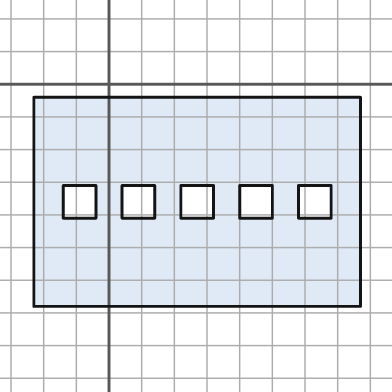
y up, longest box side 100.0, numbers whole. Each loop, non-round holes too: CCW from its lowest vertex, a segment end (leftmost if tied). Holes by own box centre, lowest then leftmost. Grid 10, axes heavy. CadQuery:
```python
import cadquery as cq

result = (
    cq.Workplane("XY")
    .moveTo(-23.0, -68.0)
    .lineTo(77.0, -68.0)
    .lineTo(77.0, -4.0)
    .lineTo(-23.0, -4.0)
    .close()
    .moveTo(-14.0, -41.0)
    .lineTo(-4.0, -41.0)
    .lineTo(-4.0, -31.0)
    .lineTo(-14.0, -31.0)
    .close()
    .moveTo(4.0, -41.0)
    .lineTo(14.0, -41.0)
    .lineTo(14.0, -31.0)
    .lineTo(4.0, -31.0)
    .close()
    .moveTo(22.0, -41.0)
    .lineTo(32.0, -41.0)
    .lineTo(32.0, -31.0)
    .lineTo(22.0, -31.0)
    .close()
    .moveTo(40.0, -41.0)
    .lineTo(50.0, -41.0)
    .lineTo(50.0, -31.0)
    .lineTo(40.0, -31.0)
    .close()
    .moveTo(58.0, -41.0)
    .lineTo(68.0, -41.0)
    .lineTo(68.0, -31.0)
    .lineTo(58.0, -31.0)
    .close()
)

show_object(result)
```